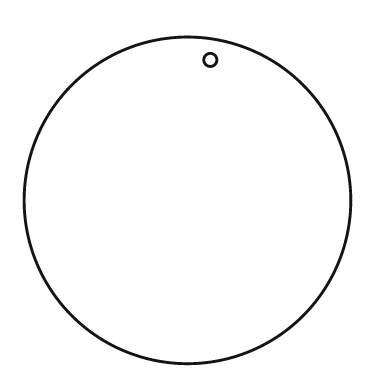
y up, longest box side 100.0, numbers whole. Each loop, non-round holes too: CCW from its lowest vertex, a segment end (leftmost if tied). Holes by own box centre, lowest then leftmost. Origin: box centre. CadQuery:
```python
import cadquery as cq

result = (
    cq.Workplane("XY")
    .moveTo(0.0, 0.0)
    .circle(50.0)
    .moveTo(7.0, 43.0)
    .circle(2.0)
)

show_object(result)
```